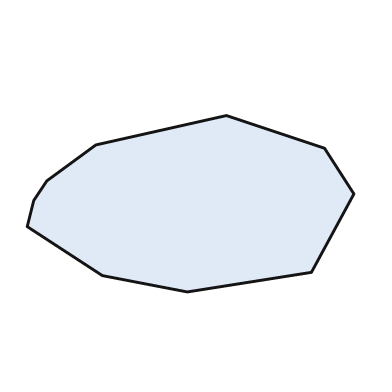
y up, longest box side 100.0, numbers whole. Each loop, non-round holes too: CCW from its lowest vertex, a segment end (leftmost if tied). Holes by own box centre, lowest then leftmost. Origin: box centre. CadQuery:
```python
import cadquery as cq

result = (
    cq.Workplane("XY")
    .moveTo(-1.0, -27.0)
    .lineTo(37.0, -21.0)
    .lineTo(50.0, 3.0)
    .lineTo(41.0, 17.0)
    .lineTo(11.0, 27.0)
    .lineTo(-29.0, 18.0)
    .lineTo(-44.0, 7.0)
    .lineTo(-48.0, 1.0)
    .lineTo(-50.0, -7.0)
    .lineTo(-27.0, -22.0)
    .close()
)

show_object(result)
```